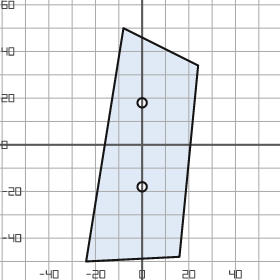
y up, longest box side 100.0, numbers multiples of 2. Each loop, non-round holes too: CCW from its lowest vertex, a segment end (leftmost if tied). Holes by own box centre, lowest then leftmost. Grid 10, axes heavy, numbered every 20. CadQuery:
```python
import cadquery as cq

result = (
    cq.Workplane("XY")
    .moveTo(-24.0, -50.0)
    .lineTo(16.0, -48.0)
    .lineTo(24.0, 34.0)
    .lineTo(-8.0, 50.0)
    .close()
    .moveTo(0.0, -18.0)
    .circle(2.0)
    .moveTo(0.0, 18.0)
    .circle(2.0)
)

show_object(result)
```